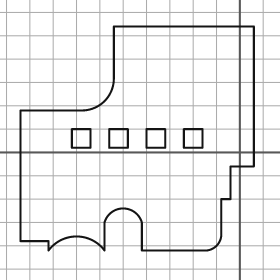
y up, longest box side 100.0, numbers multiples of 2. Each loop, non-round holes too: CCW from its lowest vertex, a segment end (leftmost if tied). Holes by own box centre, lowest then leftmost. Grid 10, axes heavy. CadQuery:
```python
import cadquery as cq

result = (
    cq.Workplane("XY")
    .moveTo(-82.0, -42.0)
    .threePointArc((-70.0, -36.0), (-58.0, -42.0))
    .lineTo(-58.0, -30.0)
    .threePointArc((-50.0, -24.0), (-42.0, -30.0))
    .lineTo(-42.0, -42.0)
    .lineTo(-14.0, -42.0)
    .threePointArc((-10.0, -40.0), (-8.0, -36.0))
    .lineTo(-8.0, -20.0)
    .lineTo(-4.0, -20.0)
    .lineTo(-4.0, -6.0)
    .lineTo(6.0, -6.0)
    .lineTo(6.0, 54.0)
    .lineTo(-54.0, 54.0)
    .lineTo(-54.0, 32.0)
    .threePointArc((-58.0, 22.0), (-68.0, 18.0))
    .lineTo(-94.0, 18.0)
    .lineTo(-94.0, -38.0)
    .lineTo(-82.0, -38.0)
    .close()
    .moveTo(-72.0, 2.0)
    .lineTo(-64.0, 2.0)
    .lineTo(-64.0, 10.0)
    .lineTo(-72.0, 10.0)
    .close()
    .moveTo(-56.0, 2.0)
    .lineTo(-48.0, 2.0)
    .lineTo(-48.0, 10.0)
    .lineTo(-56.0, 10.0)
    .close()
    .moveTo(-40.0, 2.0)
    .lineTo(-32.0, 2.0)
    .lineTo(-32.0, 10.0)
    .lineTo(-40.0, 10.0)
    .close()
    .moveTo(-24.0, 2.0)
    .lineTo(-16.0, 2.0)
    .lineTo(-16.0, 10.0)
    .lineTo(-24.0, 10.0)
    .close()
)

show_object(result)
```